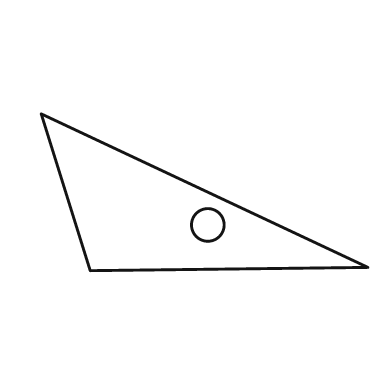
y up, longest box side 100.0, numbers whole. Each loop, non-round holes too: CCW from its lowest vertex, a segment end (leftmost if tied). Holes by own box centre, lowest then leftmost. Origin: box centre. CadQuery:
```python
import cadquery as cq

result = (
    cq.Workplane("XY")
    .moveTo(-35.0, -24.0)
    .lineTo(50.0, -23.0)
    .lineTo(-50.0, 24.0)
    .close()
    .moveTo(1.0, -10.0)
    .circle(5.0)
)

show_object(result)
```